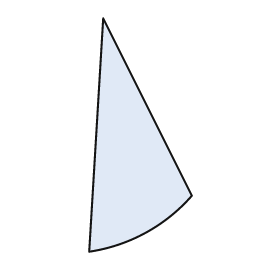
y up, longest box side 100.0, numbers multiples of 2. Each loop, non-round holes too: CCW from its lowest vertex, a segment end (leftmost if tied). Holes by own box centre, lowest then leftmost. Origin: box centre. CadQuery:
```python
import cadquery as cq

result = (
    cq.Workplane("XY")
    .moveTo(-22.0, -50.0)
    .threePointArc((2.0, -42.0), (22.0, -26.0))
    .lineTo(-16.0, 50.0)
    .close()
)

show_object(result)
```